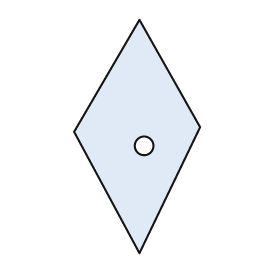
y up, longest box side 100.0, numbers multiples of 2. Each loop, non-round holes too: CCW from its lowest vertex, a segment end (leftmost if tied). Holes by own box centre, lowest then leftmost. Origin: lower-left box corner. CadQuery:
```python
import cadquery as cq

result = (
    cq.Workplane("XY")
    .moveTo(28.0, 0.0)
    .lineTo(54.0, 54.0)
    .lineTo(28.0, 100.0)
    .lineTo(0.0, 52.0)
    .close()
    .moveTo(30.0, 46.0)
    .circle(4.0)
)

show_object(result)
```